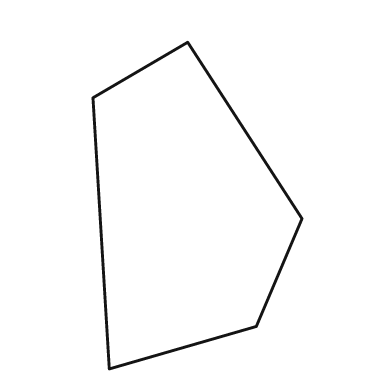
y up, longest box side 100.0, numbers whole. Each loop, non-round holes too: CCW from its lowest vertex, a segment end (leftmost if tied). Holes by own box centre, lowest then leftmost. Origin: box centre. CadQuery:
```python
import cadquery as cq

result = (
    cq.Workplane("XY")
    .moveTo(-27.0, -50.0)
    .lineTo(18.0, -37.0)
    .lineTo(32.0, -4.0)
    .lineTo(-3.0, 50.0)
    .lineTo(-32.0, 33.0)
    .close()
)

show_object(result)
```